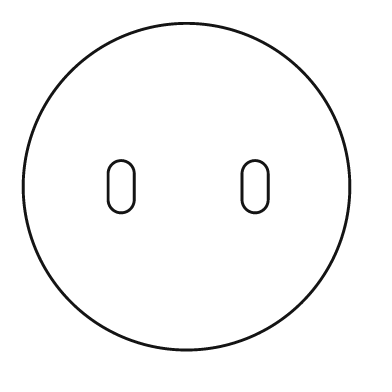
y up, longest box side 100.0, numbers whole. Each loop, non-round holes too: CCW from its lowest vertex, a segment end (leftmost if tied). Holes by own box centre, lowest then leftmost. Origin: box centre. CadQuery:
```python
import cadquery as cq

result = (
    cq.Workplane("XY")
    .moveTo(0.0, 0.0)
    .circle(50.0)
    .moveTo(-24.0, -4.0)
    .threePointArc((-20.0, -8.0), (-16.0, -4.0))
    .lineTo(-16.0, 4.0)
    .threePointArc((-20.0, 8.0), (-24.0, 4.0))
    .close()
    .moveTo(17.0, -4.0)
    .threePointArc((21.0, -8.0), (25.0, -4.0))
    .lineTo(25.0, 4.0)
    .threePointArc((21.0, 8.0), (17.0, 4.0))
    .close()
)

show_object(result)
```